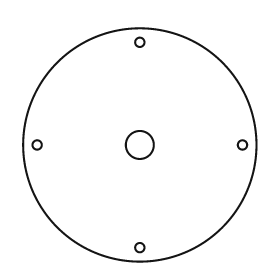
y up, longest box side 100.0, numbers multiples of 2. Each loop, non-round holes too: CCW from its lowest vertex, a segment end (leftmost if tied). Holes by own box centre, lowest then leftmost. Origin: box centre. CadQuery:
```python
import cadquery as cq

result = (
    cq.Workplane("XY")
    .moveTo(0.0, 0.0)
    .circle(50.0)
    .moveTo(0.0, -44.0)
    .circle(2.0)
    .moveTo(-44.0, 0.0)
    .circle(2.0)
    .moveTo(0.0, 0.0)
    .circle(6.0)
    .moveTo(44.0, 0.0)
    .circle(2.0)
    .moveTo(0.0, 44.0)
    .circle(2.0)
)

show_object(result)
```